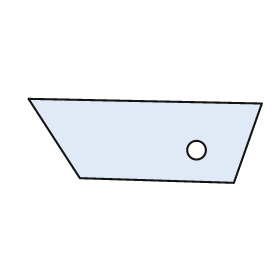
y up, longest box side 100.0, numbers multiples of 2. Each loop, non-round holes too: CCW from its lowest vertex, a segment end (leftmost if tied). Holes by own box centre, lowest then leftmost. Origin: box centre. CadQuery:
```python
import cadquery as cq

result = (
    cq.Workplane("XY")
    .moveTo(38.0, -18.0)
    .lineTo(50.0, 16.0)
    .lineTo(-50.0, 18.0)
    .lineTo(-28.0, -16.0)
    .close()
    .moveTo(22.0, -4.0)
    .circle(4.0)
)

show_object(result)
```